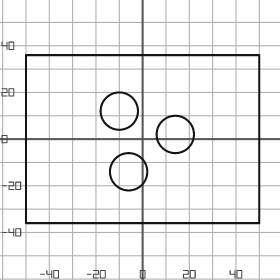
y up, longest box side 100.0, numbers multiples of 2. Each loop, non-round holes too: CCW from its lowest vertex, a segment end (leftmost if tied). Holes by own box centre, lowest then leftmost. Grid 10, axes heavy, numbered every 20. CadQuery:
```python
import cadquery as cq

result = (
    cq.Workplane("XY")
    .moveTo(-50.0, -36.0)
    .lineTo(50.0, -36.0)
    .lineTo(50.0, 36.0)
    .lineTo(-50.0, 36.0)
    .close()
    .moveTo(-6.0, -14.0)
    .circle(8.0)
    .moveTo(14.0, 2.0)
    .circle(8.0)
    .moveTo(-10.0, 12.0)
    .circle(8.0)
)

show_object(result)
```